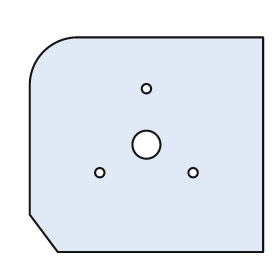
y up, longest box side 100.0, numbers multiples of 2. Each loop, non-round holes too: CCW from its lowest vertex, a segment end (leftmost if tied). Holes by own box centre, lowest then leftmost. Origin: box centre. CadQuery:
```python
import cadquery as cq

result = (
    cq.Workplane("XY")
    .moveTo(-38.0, -46.0)
    .lineTo(50.0, -46.0)
    .lineTo(50.0, 46.0)
    .lineTo(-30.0, 46.0)
    .threePointArc((-44.0, 40.0), (-50.0, 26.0))
    .lineTo(-50.0, -30.0)
    .close()
    .moveTo(-20.0, -12.0)
    .circle(2.0)
    .moveTo(20.0, -12.0)
    .circle(2.0)
    .moveTo(0.0, 0.0)
    .circle(6.0)
    .moveTo(0.0, 24.0)
    .circle(2.0)
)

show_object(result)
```